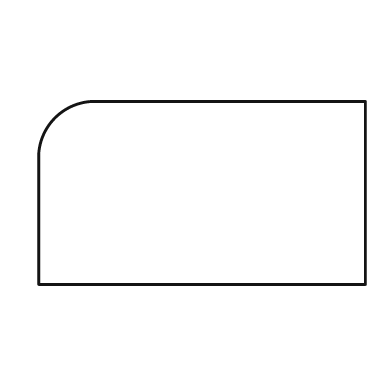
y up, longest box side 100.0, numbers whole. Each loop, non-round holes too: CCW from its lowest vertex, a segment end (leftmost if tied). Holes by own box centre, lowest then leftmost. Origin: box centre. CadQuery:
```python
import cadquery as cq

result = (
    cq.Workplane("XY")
    .moveTo(-50.0, -28.0)
    .lineTo(50.0, -28.0)
    .lineTo(50.0, 28.0)
    .lineTo(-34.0, 28.0)
    .threePointArc((-45.0, 23.0), (-50.0, 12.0))
    .close()
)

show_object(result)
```